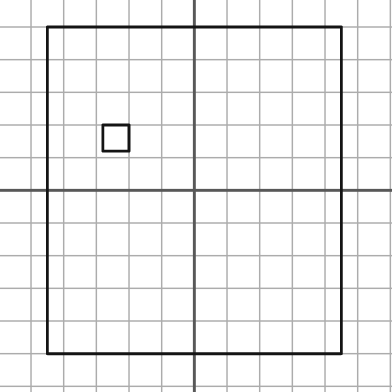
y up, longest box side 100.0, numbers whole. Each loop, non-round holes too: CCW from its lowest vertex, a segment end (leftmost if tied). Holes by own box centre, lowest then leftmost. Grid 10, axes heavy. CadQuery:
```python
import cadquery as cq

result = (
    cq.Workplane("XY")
    .moveTo(-45.0, -50.0)
    .lineTo(45.0, -50.0)
    .lineTo(45.0, 50.0)
    .lineTo(-45.0, 50.0)
    .close()
    .moveTo(-28.0, 12.0)
    .lineTo(-20.0, 12.0)
    .lineTo(-20.0, 20.0)
    .lineTo(-28.0, 20.0)
    .close()
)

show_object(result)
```